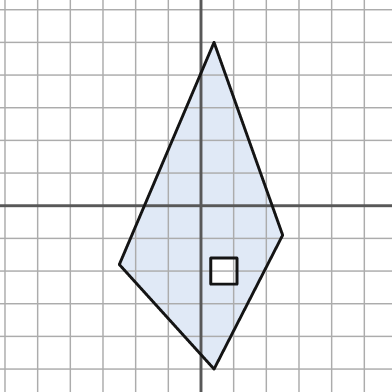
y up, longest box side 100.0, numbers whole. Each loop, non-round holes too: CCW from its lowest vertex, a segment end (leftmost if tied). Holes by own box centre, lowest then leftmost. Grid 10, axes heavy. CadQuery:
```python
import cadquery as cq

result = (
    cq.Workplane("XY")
    .moveTo(4.0, -50.0)
    .lineTo(25.0, -9.0)
    .lineTo(4.0, 50.0)
    .lineTo(-25.0, -18.0)
    .close()
    .moveTo(3.0, -24.0)
    .lineTo(11.0, -24.0)
    .lineTo(11.0, -16.0)
    .lineTo(3.0, -16.0)
    .close()
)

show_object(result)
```